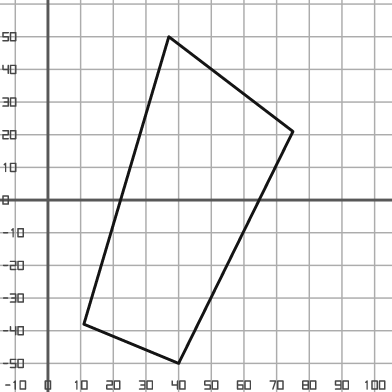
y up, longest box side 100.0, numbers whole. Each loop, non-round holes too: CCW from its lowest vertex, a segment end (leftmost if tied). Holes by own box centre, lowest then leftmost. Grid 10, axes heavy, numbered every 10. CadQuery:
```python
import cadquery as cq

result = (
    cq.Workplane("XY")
    .moveTo(40.0, -50.0)
    .lineTo(75.0, 21.0)
    .lineTo(37.0, 50.0)
    .lineTo(11.0, -38.0)
    .close()
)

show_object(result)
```